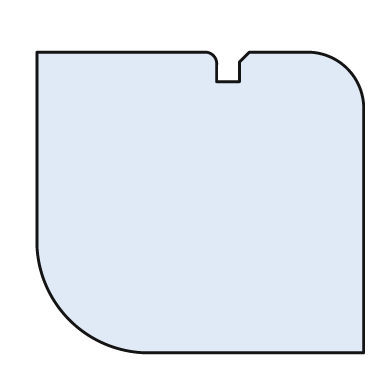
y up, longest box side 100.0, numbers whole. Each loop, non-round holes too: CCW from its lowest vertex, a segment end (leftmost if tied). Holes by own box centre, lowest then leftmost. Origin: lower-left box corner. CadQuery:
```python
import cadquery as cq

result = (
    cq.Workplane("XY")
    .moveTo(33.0, 0.0)
    .lineTo(100.0, 0.0)
    .lineTo(100.0, 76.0)
    .threePointArc((95.0, 87.0), (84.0, 92.0))
    .lineTo(65.0, 92.0)
    .lineTo(62.0, 89.0)
    .lineTo(62.0, 83.0)
    .lineTo(55.0, 83.0)
    .lineTo(55.0, 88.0)
    .threePointArc((54.0, 91.0), (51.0, 92.0))
    .lineTo(0.0, 92.0)
    .lineTo(0.0, 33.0)
    .threePointArc((10.0, 10.0), (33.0, 0.0))
    .close()
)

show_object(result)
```